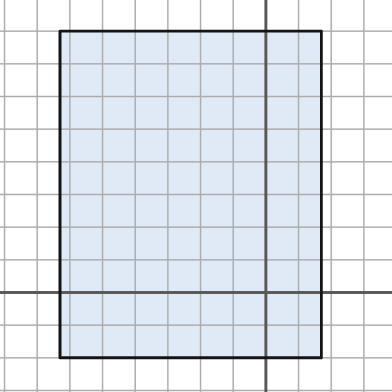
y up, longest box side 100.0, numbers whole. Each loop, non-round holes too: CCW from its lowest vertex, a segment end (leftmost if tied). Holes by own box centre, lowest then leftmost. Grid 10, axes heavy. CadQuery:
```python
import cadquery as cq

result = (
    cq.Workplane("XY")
    .moveTo(-63.0, -20.0)
    .lineTo(17.0, -20.0)
    .lineTo(17.0, 80.0)
    .lineTo(-63.0, 80.0)
    .close()
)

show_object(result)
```